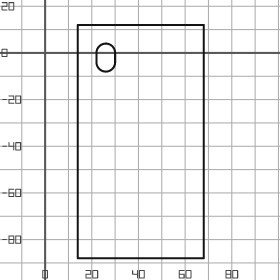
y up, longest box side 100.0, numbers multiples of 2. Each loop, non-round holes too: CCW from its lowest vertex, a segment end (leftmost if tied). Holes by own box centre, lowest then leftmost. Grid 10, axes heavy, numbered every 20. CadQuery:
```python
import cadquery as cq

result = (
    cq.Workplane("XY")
    .moveTo(14.0, -88.0)
    .lineTo(68.0, -88.0)
    .lineTo(68.0, 12.0)
    .lineTo(14.0, 12.0)
    .close()
    .moveTo(22.0, -4.0)
    .threePointArc((26.0, -8.0), (30.0, -4.0))
    .lineTo(30.0, 0.0)
    .threePointArc((26.0, 4.0), (22.0, 0.0))
    .close()
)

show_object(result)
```